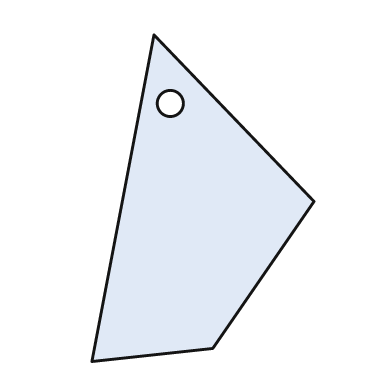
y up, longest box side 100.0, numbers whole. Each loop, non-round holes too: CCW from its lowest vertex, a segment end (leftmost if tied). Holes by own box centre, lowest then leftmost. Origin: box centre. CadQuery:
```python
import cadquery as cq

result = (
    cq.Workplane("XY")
    .moveTo(-34.0, -50.0)
    .lineTo(3.0, -46.0)
    .lineTo(34.0, -1.0)
    .lineTo(-15.0, 50.0)
    .close()
    .moveTo(-10.0, 29.0)
    .circle(4.0)
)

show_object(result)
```